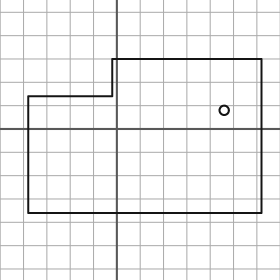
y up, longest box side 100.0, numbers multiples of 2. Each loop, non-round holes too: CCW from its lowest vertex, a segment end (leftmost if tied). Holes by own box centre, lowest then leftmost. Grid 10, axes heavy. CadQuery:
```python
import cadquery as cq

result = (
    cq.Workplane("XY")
    .moveTo(-38.0, -36.0)
    .lineTo(62.0, -36.0)
    .lineTo(62.0, 30.0)
    .lineTo(-2.0, 30.0)
    .lineTo(-2.0, 14.0)
    .lineTo(-38.0, 14.0)
    .close()
    .moveTo(46.0, 8.0)
    .circle(2.0)
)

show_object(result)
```